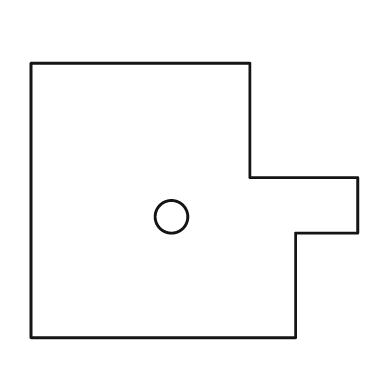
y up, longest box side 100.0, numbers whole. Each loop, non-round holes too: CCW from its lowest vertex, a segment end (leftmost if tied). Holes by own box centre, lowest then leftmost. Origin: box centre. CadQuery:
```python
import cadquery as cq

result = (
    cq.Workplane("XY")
    .moveTo(-50.0, -42.0)
    .lineTo(31.0, -42.0)
    .lineTo(31.0, -10.0)
    .lineTo(50.0, -10.0)
    .lineTo(50.0, 7.0)
    .lineTo(17.0, 7.0)
    .lineTo(17.0, 42.0)
    .lineTo(-50.0, 42.0)
    .close()
    .moveTo(-7.0, -5.0)
    .circle(5.0)
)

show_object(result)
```